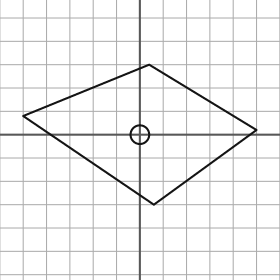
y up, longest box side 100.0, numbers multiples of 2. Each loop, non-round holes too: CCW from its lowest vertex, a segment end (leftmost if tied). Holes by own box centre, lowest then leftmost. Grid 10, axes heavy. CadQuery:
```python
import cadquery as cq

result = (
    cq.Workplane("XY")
    .moveTo(6.0, -30.0)
    .lineTo(50.0, 2.0)
    .lineTo(4.0, 30.0)
    .lineTo(-50.0, 8.0)
    .close()
    .moveTo(0.0, 0.0)
    .circle(4.0)
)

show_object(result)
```